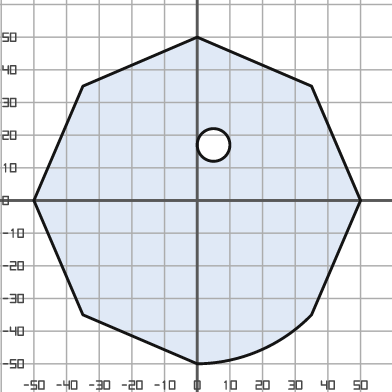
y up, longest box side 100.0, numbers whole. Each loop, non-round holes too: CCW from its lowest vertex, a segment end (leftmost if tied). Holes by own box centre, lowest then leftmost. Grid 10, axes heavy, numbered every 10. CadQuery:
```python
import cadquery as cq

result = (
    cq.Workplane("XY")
    .moveTo(0.0, -50.0)
    .threePointArc((19.0, -46.0), (35.0, -35.0))
    .lineTo(50.0, 0.0)
    .lineTo(35.0, 35.0)
    .lineTo(0.0, 50.0)
    .lineTo(-35.0, 35.0)
    .lineTo(-50.0, 0.0)
    .lineTo(-35.0, -35.0)
    .close()
    .moveTo(5.0, 17.0)
    .circle(5.0)
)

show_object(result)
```